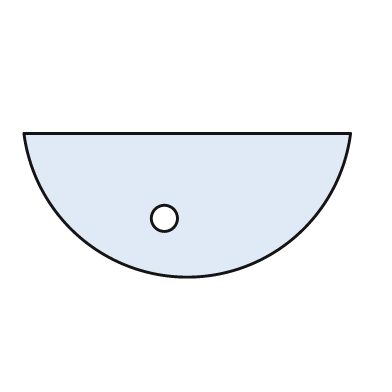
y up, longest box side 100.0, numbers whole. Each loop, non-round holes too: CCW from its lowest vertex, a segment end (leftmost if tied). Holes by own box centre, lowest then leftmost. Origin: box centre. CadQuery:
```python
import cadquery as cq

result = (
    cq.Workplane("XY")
    .moveTo(-50.0, 22.0)
    .threePointArc((0.0, -22.0), (50.0, 22.0))
    .close()
    .moveTo(-7.0, -4.0)
    .circle(4.0)
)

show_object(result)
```